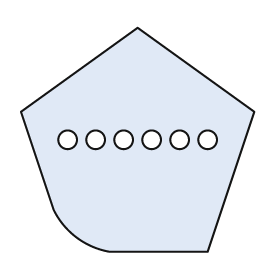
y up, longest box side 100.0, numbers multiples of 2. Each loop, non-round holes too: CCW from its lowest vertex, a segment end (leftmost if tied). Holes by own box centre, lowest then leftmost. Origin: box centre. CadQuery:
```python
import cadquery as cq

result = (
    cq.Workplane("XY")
    .moveTo(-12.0, -48.0)
    .lineTo(30.0, -48.0)
    .lineTo(50.0, 12.0)
    .lineTo(0.0, 48.0)
    .lineTo(-50.0, 12.0)
    .lineTo(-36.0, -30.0)
    .threePointArc((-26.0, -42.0), (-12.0, -48.0))
    .close()
    .moveTo(-30.0, 0.0)
    .circle(4.0)
    .moveTo(-18.0, 0.0)
    .circle(4.0)
    .moveTo(-6.0, 0.0)
    .circle(4.0)
    .moveTo(6.0, 0.0)
    .circle(4.0)
    .moveTo(18.0, 0.0)
    .circle(4.0)
    .moveTo(30.0, 0.0)
    .circle(4.0)
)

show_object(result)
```